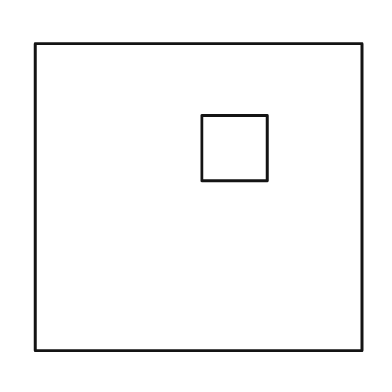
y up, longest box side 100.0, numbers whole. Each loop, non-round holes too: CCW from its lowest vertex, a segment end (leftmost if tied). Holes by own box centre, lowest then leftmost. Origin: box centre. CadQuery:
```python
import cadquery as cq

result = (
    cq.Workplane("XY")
    .moveTo(-50.0, -47.0)
    .lineTo(50.0, -47.0)
    .lineTo(50.0, 47.0)
    .lineTo(-50.0, 47.0)
    .close()
    .moveTo(1.0, 5.0)
    .lineTo(21.0, 5.0)
    .lineTo(21.0, 25.0)
    .lineTo(1.0, 25.0)
    .close()
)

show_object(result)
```